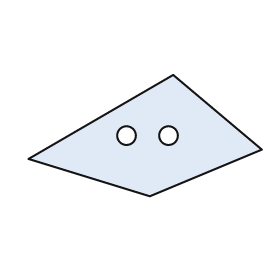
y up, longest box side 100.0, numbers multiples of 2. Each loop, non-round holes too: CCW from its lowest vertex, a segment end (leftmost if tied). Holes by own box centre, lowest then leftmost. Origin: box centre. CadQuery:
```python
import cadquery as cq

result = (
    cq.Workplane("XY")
    .moveTo(2.0, -26.0)
    .lineTo(50.0, -6.0)
    .lineTo(12.0, 26.0)
    .lineTo(-50.0, -10.0)
    .close()
    .moveTo(-8.0, 0.0)
    .circle(4.0)
    .moveTo(10.0, 0.0)
    .circle(4.0)
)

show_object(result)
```